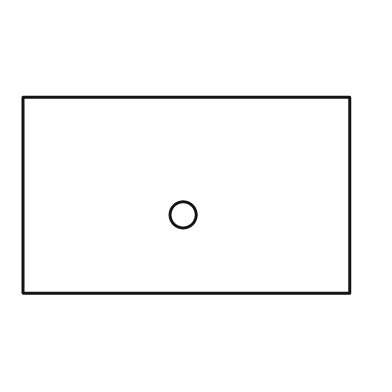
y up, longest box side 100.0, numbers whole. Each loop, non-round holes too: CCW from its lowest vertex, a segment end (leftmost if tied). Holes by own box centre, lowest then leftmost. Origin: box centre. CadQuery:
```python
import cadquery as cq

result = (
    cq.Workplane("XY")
    .moveTo(-50.0, -30.0)
    .lineTo(50.0, -30.0)
    .lineTo(50.0, 30.0)
    .lineTo(-50.0, 30.0)
    .close()
    .moveTo(-1.0, -6.0)
    .circle(4.0)
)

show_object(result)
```